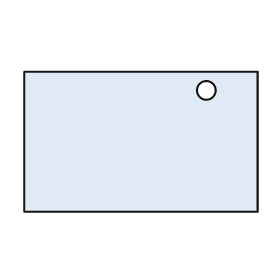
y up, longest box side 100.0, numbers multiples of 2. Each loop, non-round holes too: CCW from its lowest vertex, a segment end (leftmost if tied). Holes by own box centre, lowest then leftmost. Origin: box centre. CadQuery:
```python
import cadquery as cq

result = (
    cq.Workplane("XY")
    .moveTo(-50.0, -30.0)
    .lineTo(50.0, -30.0)
    .lineTo(50.0, 30.0)
    .lineTo(-50.0, 30.0)
    .close()
    .moveTo(28.0, 22.0)
    .circle(4.0)
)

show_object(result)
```